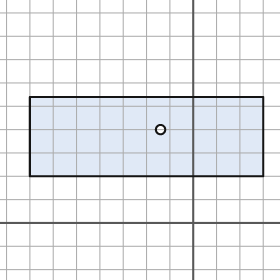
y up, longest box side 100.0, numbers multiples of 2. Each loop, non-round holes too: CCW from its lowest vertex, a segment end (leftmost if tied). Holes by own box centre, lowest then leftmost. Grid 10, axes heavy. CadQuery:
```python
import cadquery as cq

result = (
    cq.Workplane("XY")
    .moveTo(-70.0, 20.0)
    .lineTo(30.0, 20.0)
    .lineTo(30.0, 54.0)
    .lineTo(-70.0, 54.0)
    .close()
    .moveTo(-14.0, 40.0)
    .circle(2.0)
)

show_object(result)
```